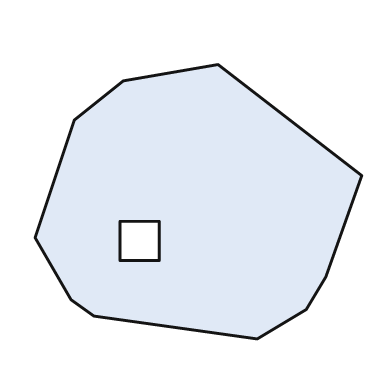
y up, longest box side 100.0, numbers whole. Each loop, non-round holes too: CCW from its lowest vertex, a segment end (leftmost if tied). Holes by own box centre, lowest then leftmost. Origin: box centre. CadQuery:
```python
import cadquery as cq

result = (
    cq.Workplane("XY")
    .moveTo(18.0, -42.0)
    .lineTo(33.0, -33.0)
    .lineTo(39.0, -23.0)
    .lineTo(50.0, 8.0)
    .lineTo(6.0, 42.0)
    .lineTo(-23.0, 37.0)
    .lineTo(-38.0, 25.0)
    .lineTo(-50.0, -11.0)
    .lineTo(-39.0, -30.0)
    .lineTo(-32.0, -35.0)
    .close()
    .moveTo(-24.0, -18.0)
    .lineTo(-12.0, -18.0)
    .lineTo(-12.0, -6.0)
    .lineTo(-24.0, -6.0)
    .close()
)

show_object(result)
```